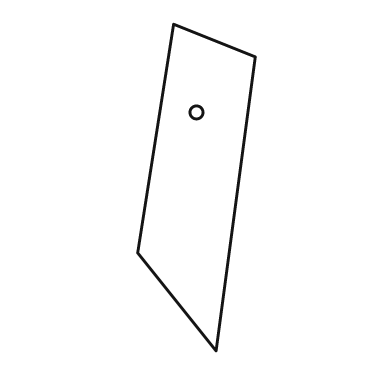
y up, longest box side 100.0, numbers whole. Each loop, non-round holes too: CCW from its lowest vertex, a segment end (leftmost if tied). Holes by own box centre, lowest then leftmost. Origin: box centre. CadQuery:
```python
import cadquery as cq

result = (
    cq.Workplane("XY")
    .moveTo(6.0, -50.0)
    .lineTo(18.0, 40.0)
    .lineTo(-7.0, 50.0)
    .lineTo(-18.0, -20.0)
    .close()
    .moveTo(0.0, 23.0)
    .circle(2.0)
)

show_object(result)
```